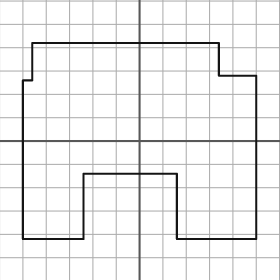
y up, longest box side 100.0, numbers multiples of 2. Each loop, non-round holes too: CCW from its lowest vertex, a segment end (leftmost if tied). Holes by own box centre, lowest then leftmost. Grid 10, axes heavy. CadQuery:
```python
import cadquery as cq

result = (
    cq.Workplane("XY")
    .moveTo(-50.0, -42.0)
    .lineTo(-24.0, -42.0)
    .lineTo(-24.0, -14.0)
    .lineTo(16.0, -14.0)
    .lineTo(16.0, -42.0)
    .lineTo(50.0, -42.0)
    .lineTo(50.0, 28.0)
    .lineTo(34.0, 28.0)
    .lineTo(34.0, 42.0)
    .lineTo(-46.0, 42.0)
    .lineTo(-46.0, 26.0)
    .lineTo(-50.0, 26.0)
    .close()
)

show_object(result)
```